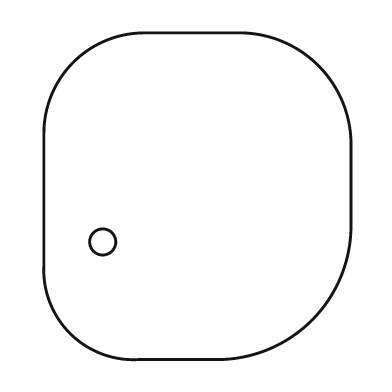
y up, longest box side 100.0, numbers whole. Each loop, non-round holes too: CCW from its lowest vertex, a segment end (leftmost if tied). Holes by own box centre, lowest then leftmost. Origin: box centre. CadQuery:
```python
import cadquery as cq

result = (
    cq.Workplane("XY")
    .moveTo(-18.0, -50.0)
    .lineTo(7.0, -50.0)
    .threePointArc((35.0, -38.0), (47.0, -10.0))
    .lineTo(47.0, 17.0)
    .threePointArc((37.0, 40.0), (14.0, 50.0))
    .lineTo(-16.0, 50.0)
    .threePointArc((-38.0, 41.0), (-47.0, 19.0))
    .lineTo(-47.0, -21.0)
    .threePointArc((-39.0, -42.0), (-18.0, -50.0))
    .close()
    .moveTo(-29.0, -14.0)
    .circle(4.0)
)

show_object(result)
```